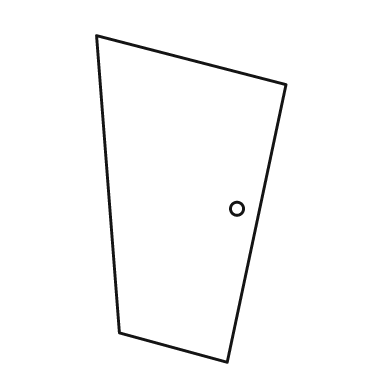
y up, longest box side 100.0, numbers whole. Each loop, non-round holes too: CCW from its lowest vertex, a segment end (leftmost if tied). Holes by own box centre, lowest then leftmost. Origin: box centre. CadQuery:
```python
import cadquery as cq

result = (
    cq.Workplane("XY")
    .moveTo(11.0, -50.0)
    .lineTo(29.0, 35.0)
    .lineTo(-29.0, 50.0)
    .lineTo(-22.0, -41.0)
    .close()
    .moveTo(14.0, -3.0)
    .circle(2.0)
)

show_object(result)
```